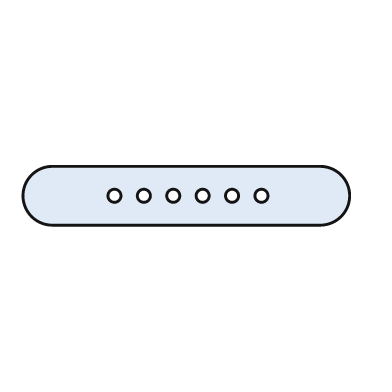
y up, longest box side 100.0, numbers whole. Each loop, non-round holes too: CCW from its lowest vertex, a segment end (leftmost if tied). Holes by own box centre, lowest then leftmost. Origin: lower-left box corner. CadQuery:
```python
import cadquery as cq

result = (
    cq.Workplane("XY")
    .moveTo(9.0, 0.0)
    .lineTo(91.0, 0.0)
    .threePointArc((100.0, 9.0), (91.0, 18.0))
    .lineTo(9.0, 18.0)
    .threePointArc((0.0, 9.0), (9.0, 0.0))
    .close()
    .moveTo(28.0, 9.0)
    .circle(2.0)
    .moveTo(37.0, 9.0)
    .circle(2.0)
    .moveTo(46.0, 9.0)
    .circle(2.0)
    .moveTo(55.0, 9.0)
    .circle(2.0)
    .moveTo(64.0, 9.0)
    .circle(2.0)
    .moveTo(73.0, 9.0)
    .circle(2.0)
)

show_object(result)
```